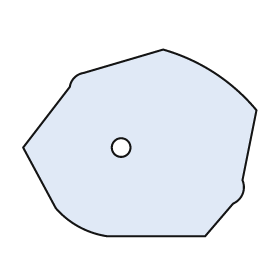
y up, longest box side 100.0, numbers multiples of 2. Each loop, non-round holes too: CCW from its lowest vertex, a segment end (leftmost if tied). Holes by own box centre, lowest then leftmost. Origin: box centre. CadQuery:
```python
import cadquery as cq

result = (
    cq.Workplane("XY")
    .moveTo(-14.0, -40.0)
    .lineTo(28.0, -40.0)
    .lineTo(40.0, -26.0)
    .threePointArc((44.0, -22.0), (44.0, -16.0))
    .lineTo(50.0, 14.0)
    .threePointArc((32.0, 30.0), (10.0, 40.0))
    .lineTo(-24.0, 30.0)
    .threePointArc((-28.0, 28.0), (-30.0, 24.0))
    .lineTo(-50.0, -2.0)
    .lineTo(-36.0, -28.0)
    .threePointArc((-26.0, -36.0), (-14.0, -40.0))
    .close()
    .moveTo(-8.0, -2.0)
    .circle(4.0)
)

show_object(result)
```